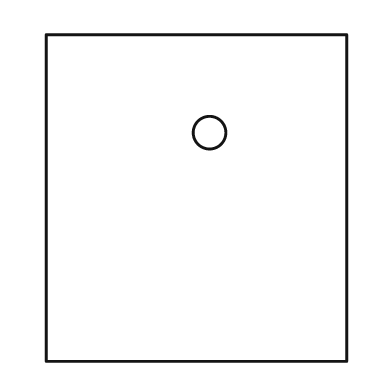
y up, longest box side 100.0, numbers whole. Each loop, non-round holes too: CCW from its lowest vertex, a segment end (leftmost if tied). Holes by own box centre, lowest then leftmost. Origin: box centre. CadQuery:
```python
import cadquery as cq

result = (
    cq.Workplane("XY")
    .moveTo(-46.0, -50.0)
    .lineTo(46.0, -50.0)
    .lineTo(46.0, 50.0)
    .lineTo(-46.0, 50.0)
    .close()
    .moveTo(4.0, 20.0)
    .circle(5.0)
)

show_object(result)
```